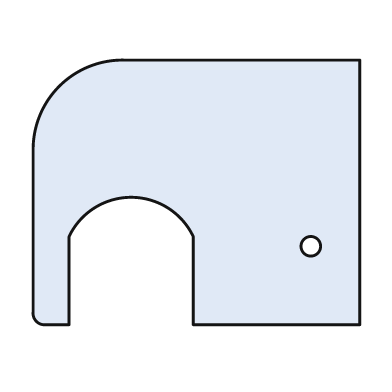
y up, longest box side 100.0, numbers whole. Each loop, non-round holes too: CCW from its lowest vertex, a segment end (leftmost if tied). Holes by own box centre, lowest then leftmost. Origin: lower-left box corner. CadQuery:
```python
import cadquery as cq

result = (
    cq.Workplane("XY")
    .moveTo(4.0, 0.0)
    .lineTo(11.0, 0.0)
    .lineTo(11.0, 27.0)
    .threePointArc((30.0, 39.0), (49.0, 27.0))
    .lineTo(49.0, 0.0)
    .lineTo(100.0, 0.0)
    .lineTo(100.0, 81.0)
    .lineTo(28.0, 81.0)
    .threePointArc((8.0, 73.0), (0.0, 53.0))
    .lineTo(0.0, 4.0)
    .threePointArc((1.0, 1.0), (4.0, 0.0))
    .close()
    .moveTo(85.0, 24.0)
    .circle(3.0)
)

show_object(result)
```